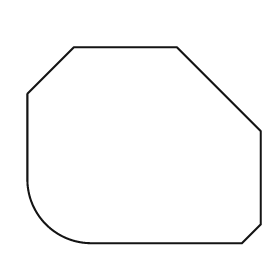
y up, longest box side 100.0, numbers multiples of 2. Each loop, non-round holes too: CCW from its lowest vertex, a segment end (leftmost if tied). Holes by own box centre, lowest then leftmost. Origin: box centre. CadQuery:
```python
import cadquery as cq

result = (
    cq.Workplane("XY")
    .moveTo(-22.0, -42.0)
    .lineTo(42.0, -42.0)
    .lineTo(50.0, -34.0)
    .lineTo(50.0, 6.0)
    .lineTo(14.0, 42.0)
    .lineTo(-30.0, 42.0)
    .lineTo(-50.0, 22.0)
    .lineTo(-50.0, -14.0)
    .threePointArc((-42.0, -34.0), (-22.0, -42.0))
    .close()
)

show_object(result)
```